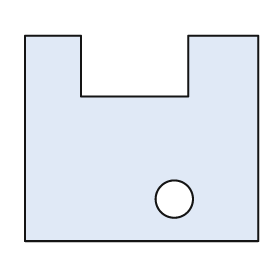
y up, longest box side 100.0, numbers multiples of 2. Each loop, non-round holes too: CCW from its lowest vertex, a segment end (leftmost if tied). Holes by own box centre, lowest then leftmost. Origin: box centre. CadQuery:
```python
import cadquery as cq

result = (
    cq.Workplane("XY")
    .moveTo(-50.0, -44.0)
    .lineTo(50.0, -44.0)
    .lineTo(50.0, 44.0)
    .lineTo(20.0, 44.0)
    .lineTo(20.0, 18.0)
    .lineTo(-26.0, 18.0)
    .lineTo(-26.0, 44.0)
    .lineTo(-50.0, 44.0)
    .close()
    .moveTo(14.0, -26.0)
    .circle(8.0)
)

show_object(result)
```